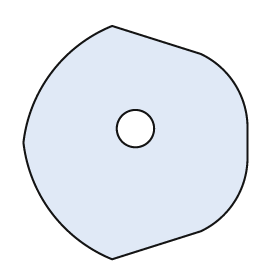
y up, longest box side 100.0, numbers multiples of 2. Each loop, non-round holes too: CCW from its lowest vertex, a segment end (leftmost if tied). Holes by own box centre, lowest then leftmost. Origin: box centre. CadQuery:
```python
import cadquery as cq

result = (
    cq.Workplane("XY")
    .moveTo(-10.0, -50.0)
    .lineTo(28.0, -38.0)
    .threePointArc((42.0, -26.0), (48.0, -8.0))
    .lineTo(48.0, 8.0)
    .threePointArc((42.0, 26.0), (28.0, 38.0))
    .lineTo(-10.0, 50.0)
    .threePointArc((-36.0, 30.0), (-48.0, 0.0))
    .threePointArc((-36.0, -30.0), (-10.0, -50.0))
    .close()
    .moveTo(0.0, 6.0)
    .circle(8.0)
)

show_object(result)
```